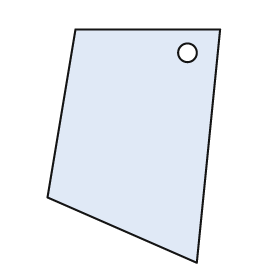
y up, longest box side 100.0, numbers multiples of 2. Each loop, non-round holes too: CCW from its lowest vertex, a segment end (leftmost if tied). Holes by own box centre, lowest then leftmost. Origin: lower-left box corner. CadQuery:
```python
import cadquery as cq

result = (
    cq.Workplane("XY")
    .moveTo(64.0, 0.0)
    .lineTo(74.0, 100.0)
    .lineTo(12.0, 100.0)
    .lineTo(0.0, 28.0)
    .close()
    .moveTo(60.0, 90.0)
    .circle(4.0)
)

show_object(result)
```